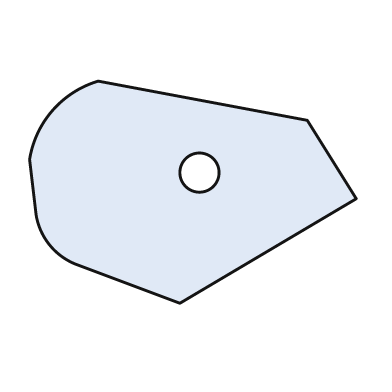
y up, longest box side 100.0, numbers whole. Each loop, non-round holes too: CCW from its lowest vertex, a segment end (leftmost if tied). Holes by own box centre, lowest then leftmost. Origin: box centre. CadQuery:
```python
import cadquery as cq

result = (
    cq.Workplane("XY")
    .moveTo(-4.0, -34.0)
    .lineTo(50.0, -2.0)
    .lineTo(35.0, 22.0)
    .lineTo(-29.0, 34.0)
    .threePointArc((-43.0, 25.0), (-50.0, 10.0))
    .lineTo(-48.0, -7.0)
    .threePointArc((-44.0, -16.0), (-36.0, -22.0))
    .close()
    .moveTo(2.0, 6.0)
    .circle(6.0)
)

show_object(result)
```